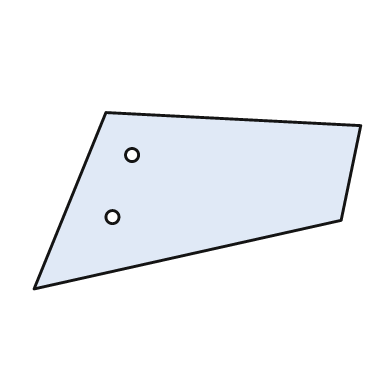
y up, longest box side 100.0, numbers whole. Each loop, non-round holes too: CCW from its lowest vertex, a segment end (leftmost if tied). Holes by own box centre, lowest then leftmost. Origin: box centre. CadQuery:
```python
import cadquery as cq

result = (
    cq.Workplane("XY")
    .moveTo(-50.0, -27.0)
    .lineTo(44.0, -6.0)
    .lineTo(50.0, 23.0)
    .lineTo(-28.0, 27.0)
    .close()
    .moveTo(-26.0, -5.0)
    .circle(2.0)
    .moveTo(-20.0, 14.0)
    .circle(2.0)
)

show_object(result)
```